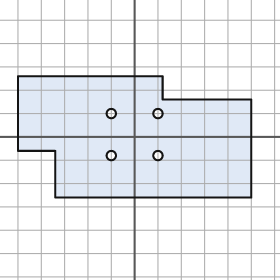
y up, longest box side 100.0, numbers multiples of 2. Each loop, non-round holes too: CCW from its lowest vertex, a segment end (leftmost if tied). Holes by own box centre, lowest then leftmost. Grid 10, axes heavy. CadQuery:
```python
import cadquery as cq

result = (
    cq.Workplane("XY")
    .moveTo(-34.0, -26.0)
    .lineTo(50.0, -26.0)
    .lineTo(50.0, 16.0)
    .lineTo(12.0, 16.0)
    .lineTo(12.0, 26.0)
    .lineTo(-50.0, 26.0)
    .lineTo(-50.0, -6.0)
    .lineTo(-34.0, -6.0)
    .close()
    .moveTo(-10.0, -8.0)
    .circle(2.0)
    .moveTo(10.0, -8.0)
    .circle(2.0)
    .moveTo(-10.0, 10.0)
    .circle(2.0)
    .moveTo(10.0, 10.0)
    .circle(2.0)
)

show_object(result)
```